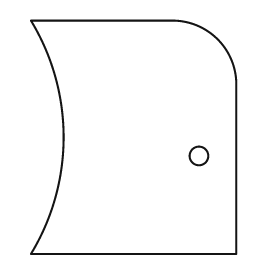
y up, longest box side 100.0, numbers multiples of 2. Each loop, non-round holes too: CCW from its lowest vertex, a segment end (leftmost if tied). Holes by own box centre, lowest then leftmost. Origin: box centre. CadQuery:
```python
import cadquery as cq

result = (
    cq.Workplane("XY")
    .moveTo(-44.0, -50.0)
    .lineTo(44.0, -50.0)
    .lineTo(44.0, 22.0)
    .threePointArc((36.0, 42.0), (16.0, 50.0))
    .lineTo(-44.0, 50.0)
    .threePointArc((-30.0, 0.0), (-44.0, -50.0))
    .close()
    .moveTo(28.0, -8.0)
    .circle(4.0)
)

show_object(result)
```